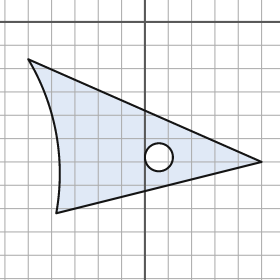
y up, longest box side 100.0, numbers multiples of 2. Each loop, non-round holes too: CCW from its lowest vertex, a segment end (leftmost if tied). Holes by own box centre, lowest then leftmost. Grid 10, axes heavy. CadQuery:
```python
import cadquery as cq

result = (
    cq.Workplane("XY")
    .moveTo(-38.0, -82.0)
    .lineTo(50.0, -60.0)
    .lineTo(-50.0, -16.0)
    .threePointArc((-38.0, -48.0), (-38.0, -82.0))
    .close()
    .moveTo(6.0, -58.0)
    .circle(6.0)
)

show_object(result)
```